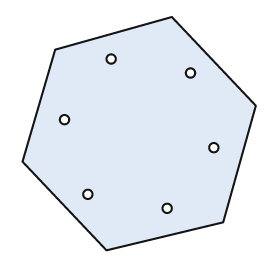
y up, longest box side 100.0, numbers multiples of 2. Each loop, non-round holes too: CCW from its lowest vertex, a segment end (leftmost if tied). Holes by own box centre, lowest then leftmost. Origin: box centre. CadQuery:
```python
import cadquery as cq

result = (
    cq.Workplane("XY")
    .moveTo(-14.0, -50.0)
    .lineTo(36.0, -38.0)
    .lineTo(50.0, 12.0)
    .lineTo(14.0, 50.0)
    .lineTo(-36.0, 36.0)
    .lineTo(-50.0, -12.0)
    .close()
    .moveTo(12.0, -32.0)
    .circle(2.0)
    .moveTo(-22.0, -26.0)
    .circle(2.0)
    .moveTo(32.0, -6.0)
    .circle(2.0)
    .moveTo(-32.0, 6.0)
    .circle(2.0)
    .moveTo(22.0, 26.0)
    .circle(2.0)
    .moveTo(-12.0, 32.0)
    .circle(2.0)
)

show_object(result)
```